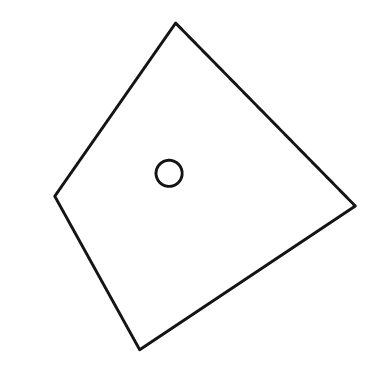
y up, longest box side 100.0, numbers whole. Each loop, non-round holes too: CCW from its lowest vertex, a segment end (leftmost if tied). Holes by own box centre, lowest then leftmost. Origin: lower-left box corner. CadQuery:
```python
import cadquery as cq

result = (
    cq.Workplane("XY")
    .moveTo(26.0, 0.0)
    .lineTo(92.0, 44.0)
    .lineTo(37.0, 100.0)
    .lineTo(0.0, 47.0)
    .close()
    .moveTo(35.0, 54.0)
    .circle(4.0)
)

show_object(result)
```